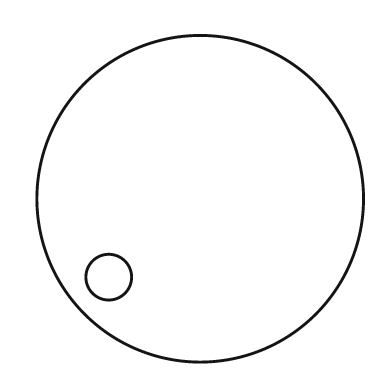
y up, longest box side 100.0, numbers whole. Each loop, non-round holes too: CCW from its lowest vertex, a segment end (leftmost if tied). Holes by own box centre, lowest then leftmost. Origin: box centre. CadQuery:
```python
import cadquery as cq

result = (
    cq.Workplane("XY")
    .moveTo(0.0, 0.0)
    .circle(50.0)
    .moveTo(-28.0, -24.0)
    .circle(7.0)
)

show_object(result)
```